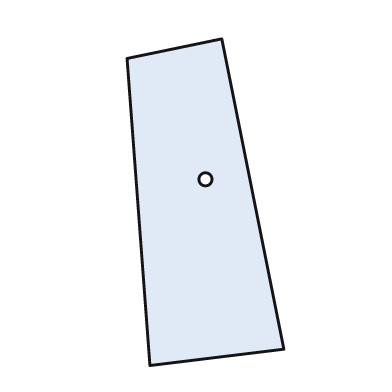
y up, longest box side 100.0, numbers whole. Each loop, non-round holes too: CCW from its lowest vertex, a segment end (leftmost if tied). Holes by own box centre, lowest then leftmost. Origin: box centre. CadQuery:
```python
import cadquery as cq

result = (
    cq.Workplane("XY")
    .moveTo(-17.0, -50.0)
    .lineTo(24.0, -45.0)
    .lineTo(5.0, 50.0)
    .lineTo(-24.0, 44.0)
    .close()
    .moveTo(0.0, 7.0)
    .circle(2.0)
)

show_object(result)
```